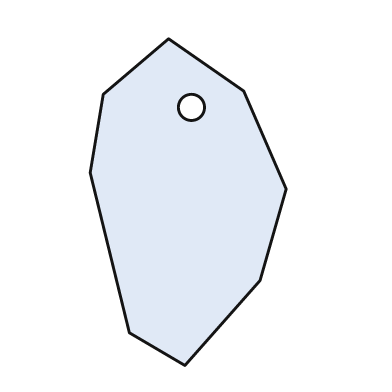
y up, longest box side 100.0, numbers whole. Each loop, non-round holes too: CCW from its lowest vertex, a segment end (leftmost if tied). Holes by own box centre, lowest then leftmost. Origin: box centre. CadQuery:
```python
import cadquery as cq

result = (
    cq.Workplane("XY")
    .moveTo(-1.0, -50.0)
    .lineTo(22.0, -24.0)
    .lineTo(30.0, 4.0)
    .lineTo(17.0, 34.0)
    .lineTo(-6.0, 50.0)
    .lineTo(-26.0, 33.0)
    .lineTo(-30.0, 9.0)
    .lineTo(-18.0, -40.0)
    .close()
    .moveTo(1.0, 29.0)
    .circle(4.0)
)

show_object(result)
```